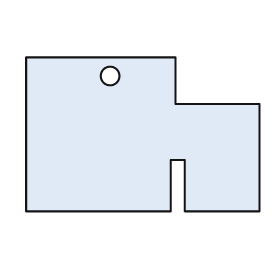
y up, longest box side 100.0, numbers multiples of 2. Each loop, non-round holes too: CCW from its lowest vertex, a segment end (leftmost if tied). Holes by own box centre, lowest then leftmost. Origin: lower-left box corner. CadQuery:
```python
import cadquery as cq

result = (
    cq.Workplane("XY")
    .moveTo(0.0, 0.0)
    .lineTo(62.0, 0.0)
    .lineTo(62.0, 22.0)
    .lineTo(68.0, 22.0)
    .lineTo(68.0, 0.0)
    .lineTo(100.0, 0.0)
    .lineTo(100.0, 46.0)
    .lineTo(64.0, 46.0)
    .lineTo(64.0, 66.0)
    .lineTo(0.0, 66.0)
    .close()
    .moveTo(36.0, 58.0)
    .circle(4.0)
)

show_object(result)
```